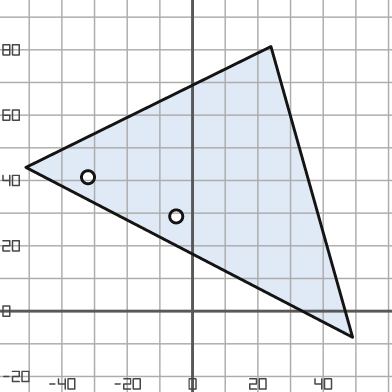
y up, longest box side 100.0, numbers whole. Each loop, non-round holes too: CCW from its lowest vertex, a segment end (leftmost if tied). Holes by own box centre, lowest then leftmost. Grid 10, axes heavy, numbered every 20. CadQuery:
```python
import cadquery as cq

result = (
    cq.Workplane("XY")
    .moveTo(49.0, -8.0)
    .lineTo(24.0, 81.0)
    .lineTo(-51.0, 44.0)
    .close()
    .moveTo(-5.0, 29.0)
    .circle(2.0)
    .moveTo(-32.0, 41.0)
    .circle(2.0)
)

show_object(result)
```